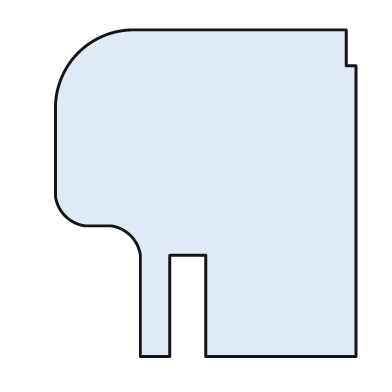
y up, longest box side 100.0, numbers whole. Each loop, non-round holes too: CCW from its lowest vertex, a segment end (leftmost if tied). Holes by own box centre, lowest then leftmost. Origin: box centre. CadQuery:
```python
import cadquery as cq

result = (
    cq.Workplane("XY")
    .moveTo(-20.0, -50.0)
    .lineTo(-11.0, -50.0)
    .lineTo(-11.0, -19.0)
    .lineTo(0.0, -19.0)
    .lineTo(0.0, -50.0)
    .lineTo(46.0, -50.0)
    .lineTo(46.0, 39.0)
    .lineTo(43.0, 39.0)
    .lineTo(43.0, 50.0)
    .lineTo(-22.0, 50.0)
    .threePointArc((-39.0, 43.0), (-46.0, 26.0))
    .lineTo(-46.0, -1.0)
    .threePointArc((-43.0, -7.0), (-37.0, -10.0))
    .lineTo(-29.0, -10.0)
    .threePointArc((-23.0, -13.0), (-20.0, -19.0))
    .close()
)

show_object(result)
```